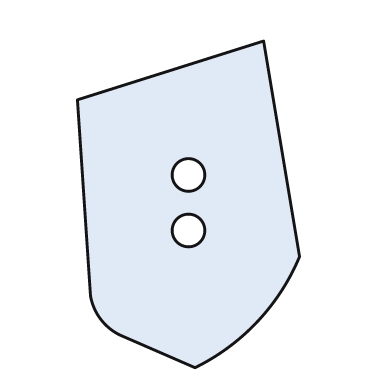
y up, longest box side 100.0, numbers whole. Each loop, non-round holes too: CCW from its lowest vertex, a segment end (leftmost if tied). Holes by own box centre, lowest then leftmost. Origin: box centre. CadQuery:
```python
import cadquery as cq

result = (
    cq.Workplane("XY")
    .moveTo(2.0, -50.0)
    .threePointArc((21.0, -36.0), (34.0, -16.0))
    .lineTo(23.0, 50.0)
    .lineTo(-34.0, 32.0)
    .lineTo(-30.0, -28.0)
    .threePointArc((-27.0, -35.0), (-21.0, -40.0))
    .close()
    .moveTo(0.0, -8.0)
    .circle(5.0)
    .moveTo(0.0, 9.0)
    .circle(5.0)
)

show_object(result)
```